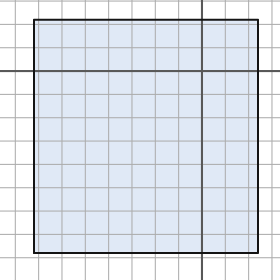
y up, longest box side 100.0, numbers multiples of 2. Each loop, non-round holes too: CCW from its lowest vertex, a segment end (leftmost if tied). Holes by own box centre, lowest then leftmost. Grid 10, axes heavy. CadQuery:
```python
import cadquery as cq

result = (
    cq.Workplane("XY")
    .moveTo(-72.0, -78.0)
    .lineTo(24.0, -78.0)
    .lineTo(24.0, 22.0)
    .lineTo(-72.0, 22.0)
    .close()
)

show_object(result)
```